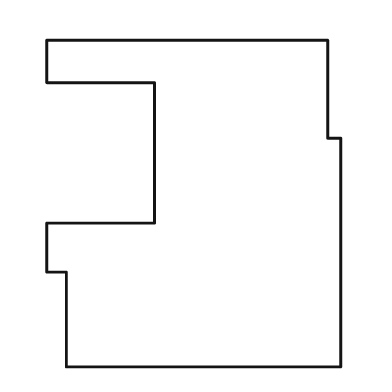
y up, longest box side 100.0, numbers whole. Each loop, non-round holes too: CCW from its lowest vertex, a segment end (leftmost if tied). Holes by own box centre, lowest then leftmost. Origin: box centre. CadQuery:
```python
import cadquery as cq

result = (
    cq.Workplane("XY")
    .moveTo(-39.0, -50.0)
    .lineTo(45.0, -50.0)
    .lineTo(45.0, 20.0)
    .lineTo(41.0, 20.0)
    .lineTo(41.0, 50.0)
    .lineTo(-45.0, 50.0)
    .lineTo(-45.0, 37.0)
    .lineTo(-12.0, 37.0)
    .lineTo(-12.0, -6.0)
    .lineTo(-45.0, -6.0)
    .lineTo(-45.0, -21.0)
    .lineTo(-39.0, -21.0)
    .close()
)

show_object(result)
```